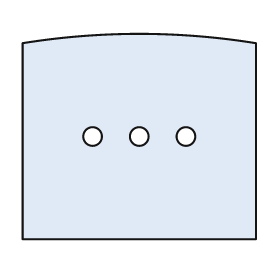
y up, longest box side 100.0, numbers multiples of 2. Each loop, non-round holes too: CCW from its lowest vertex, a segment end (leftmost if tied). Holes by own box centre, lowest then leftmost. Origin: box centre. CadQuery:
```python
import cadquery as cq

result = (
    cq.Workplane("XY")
    .moveTo(-50.0, -44.0)
    .lineTo(50.0, -44.0)
    .lineTo(50.0, 40.0)
    .threePointArc((0.0, 44.0), (-50.0, 40.0))
    .close()
    .moveTo(-20.0, 0.0)
    .circle(4.0)
    .moveTo(0.0, 0.0)
    .circle(4.0)
    .moveTo(20.0, 0.0)
    .circle(4.0)
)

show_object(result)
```